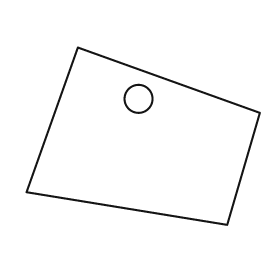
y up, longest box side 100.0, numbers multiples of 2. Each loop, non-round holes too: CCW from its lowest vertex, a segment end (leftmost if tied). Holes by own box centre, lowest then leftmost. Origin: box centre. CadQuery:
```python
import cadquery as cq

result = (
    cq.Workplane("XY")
    .moveTo(36.0, -38.0)
    .lineTo(50.0, 10.0)
    .lineTo(-28.0, 38.0)
    .lineTo(-50.0, -24.0)
    .close()
    .moveTo(-2.0, 16.0)
    .circle(6.0)
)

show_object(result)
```